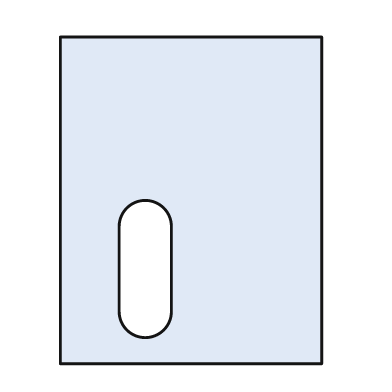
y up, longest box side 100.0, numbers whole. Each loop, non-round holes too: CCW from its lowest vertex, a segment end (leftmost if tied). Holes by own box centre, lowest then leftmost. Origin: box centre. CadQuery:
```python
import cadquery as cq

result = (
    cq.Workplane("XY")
    .moveTo(-40.0, -50.0)
    .lineTo(40.0, -50.0)
    .lineTo(40.0, 50.0)
    .lineTo(-40.0, 50.0)
    .close()
    .moveTo(-22.0, -34.0)
    .threePointArc((-14.0, -42.0), (-6.0, -34.0))
    .lineTo(-6.0, -8.0)
    .threePointArc((-14.0, 0.0), (-22.0, -8.0))
    .close()
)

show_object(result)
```